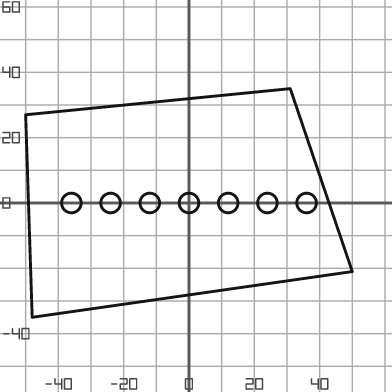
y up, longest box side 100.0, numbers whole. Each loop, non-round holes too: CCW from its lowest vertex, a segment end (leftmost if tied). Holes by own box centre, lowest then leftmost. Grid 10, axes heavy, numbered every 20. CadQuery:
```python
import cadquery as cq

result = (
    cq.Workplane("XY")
    .moveTo(-48.0, -35.0)
    .lineTo(50.0, -21.0)
    .lineTo(31.0, 35.0)
    .lineTo(-50.0, 27.0)
    .close()
    .moveTo(-36.0, 0.0)
    .circle(3.0)
    .moveTo(-24.0, 0.0)
    .circle(3.0)
    .moveTo(-12.0, 0.0)
    .circle(3.0)
    .moveTo(0.0, 0.0)
    .circle(3.0)
    .moveTo(12.0, 0.0)
    .circle(3.0)
    .moveTo(24.0, 0.0)
    .circle(3.0)
    .moveTo(36.0, 0.0)
    .circle(3.0)
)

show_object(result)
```